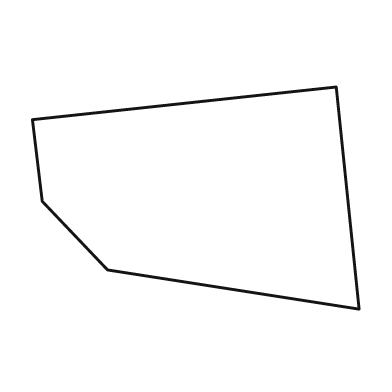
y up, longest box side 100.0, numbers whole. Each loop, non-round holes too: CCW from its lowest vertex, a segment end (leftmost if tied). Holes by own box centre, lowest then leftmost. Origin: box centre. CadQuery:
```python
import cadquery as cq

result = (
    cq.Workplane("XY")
    .moveTo(50.0, -34.0)
    .lineTo(43.0, 34.0)
    .lineTo(-50.0, 24.0)
    .lineTo(-47.0, -1.0)
    .lineTo(-27.0, -22.0)
    .close()
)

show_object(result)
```